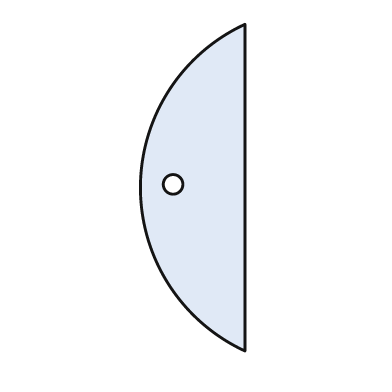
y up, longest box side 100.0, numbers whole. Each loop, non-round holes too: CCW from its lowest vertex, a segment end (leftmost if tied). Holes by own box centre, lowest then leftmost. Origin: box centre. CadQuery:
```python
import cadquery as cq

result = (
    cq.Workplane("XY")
    .moveTo(16.0, -50.0)
    .lineTo(16.0, 50.0)
    .threePointArc((-16.0, 0.0), (16.0, -50.0))
    .close()
    .moveTo(-6.0, 1.0)
    .circle(3.0)
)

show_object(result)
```